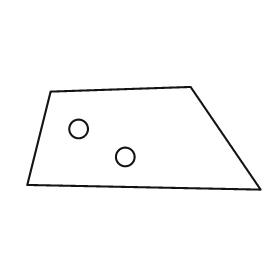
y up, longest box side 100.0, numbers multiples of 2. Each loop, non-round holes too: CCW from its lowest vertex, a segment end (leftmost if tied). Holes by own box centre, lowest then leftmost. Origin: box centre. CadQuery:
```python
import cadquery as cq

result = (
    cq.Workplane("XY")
    .moveTo(50.0, -22.0)
    .lineTo(20.0, 22.0)
    .lineTo(-40.0, 20.0)
    .lineTo(-50.0, -20.0)
    .close()
    .moveTo(-8.0, -8.0)
    .circle(4.0)
    .moveTo(-28.0, 4.0)
    .circle(4.0)
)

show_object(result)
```